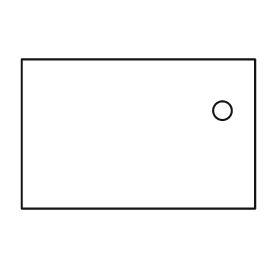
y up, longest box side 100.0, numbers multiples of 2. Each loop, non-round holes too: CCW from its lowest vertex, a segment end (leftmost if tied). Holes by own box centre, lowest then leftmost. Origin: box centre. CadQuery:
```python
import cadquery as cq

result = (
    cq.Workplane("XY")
    .moveTo(-50.0, -32.0)
    .lineTo(50.0, -32.0)
    .lineTo(50.0, 32.0)
    .lineTo(-50.0, 32.0)
    .close()
    .moveTo(36.0, 10.0)
    .circle(4.0)
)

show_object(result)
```